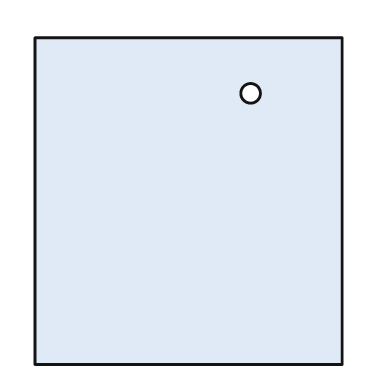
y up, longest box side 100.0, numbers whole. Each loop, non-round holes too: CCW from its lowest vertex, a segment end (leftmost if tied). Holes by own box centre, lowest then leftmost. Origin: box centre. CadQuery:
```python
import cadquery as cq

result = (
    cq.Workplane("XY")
    .moveTo(-47.0, -50.0)
    .lineTo(47.0, -50.0)
    .lineTo(47.0, 50.0)
    .lineTo(-47.0, 50.0)
    .close()
    .moveTo(19.0, 33.0)
    .circle(3.0)
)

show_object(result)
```